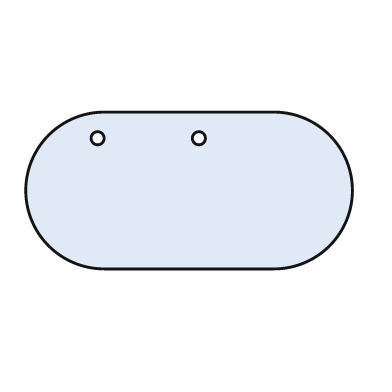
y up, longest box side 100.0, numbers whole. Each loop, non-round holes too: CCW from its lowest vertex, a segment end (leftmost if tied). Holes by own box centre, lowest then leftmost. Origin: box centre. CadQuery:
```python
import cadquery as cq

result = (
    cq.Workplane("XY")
    .moveTo(-26.0, -24.0)
    .lineTo(26.0, -24.0)
    .threePointArc((50.0, 0.0), (26.0, 24.0))
    .lineTo(-26.0, 24.0)
    .threePointArc((-50.0, 0.0), (-26.0, -24.0))
    .close()
    .moveTo(-28.0, 16.0)
    .circle(2.0)
    .moveTo(3.0, 16.0)
    .circle(2.0)
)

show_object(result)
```